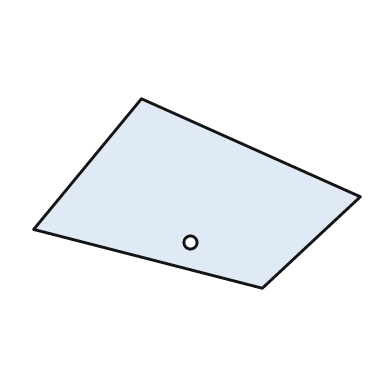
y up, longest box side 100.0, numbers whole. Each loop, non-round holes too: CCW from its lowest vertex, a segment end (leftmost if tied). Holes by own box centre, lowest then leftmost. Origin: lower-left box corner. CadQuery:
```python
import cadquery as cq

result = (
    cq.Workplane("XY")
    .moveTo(70.0, 0.0)
    .lineTo(100.0, 28.0)
    .lineTo(33.0, 58.0)
    .lineTo(0.0, 18.0)
    .close()
    .moveTo(48.0, 14.0)
    .circle(2.0)
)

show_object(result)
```